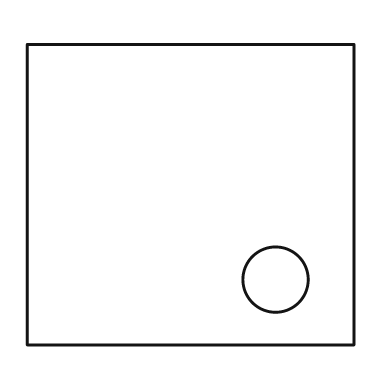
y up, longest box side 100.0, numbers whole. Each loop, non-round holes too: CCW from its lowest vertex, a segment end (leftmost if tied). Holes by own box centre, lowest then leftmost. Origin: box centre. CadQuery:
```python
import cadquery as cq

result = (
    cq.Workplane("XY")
    .moveTo(-50.0, -46.0)
    .lineTo(50.0, -46.0)
    .lineTo(50.0, 46.0)
    .lineTo(-50.0, 46.0)
    .close()
    .moveTo(26.0, -26.0)
    .circle(10.0)
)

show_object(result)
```